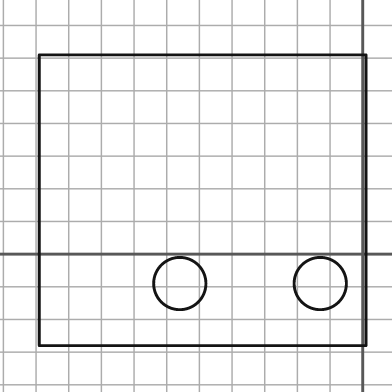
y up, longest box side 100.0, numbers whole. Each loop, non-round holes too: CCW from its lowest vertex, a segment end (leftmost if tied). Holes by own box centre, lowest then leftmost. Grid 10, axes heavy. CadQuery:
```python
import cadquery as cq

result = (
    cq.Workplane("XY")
    .moveTo(-99.0, -28.0)
    .lineTo(1.0, -28.0)
    .lineTo(1.0, 61.0)
    .lineTo(-99.0, 61.0)
    .close()
    .moveTo(-56.0, -9.0)
    .circle(8.0)
    .moveTo(-13.0, -9.0)
    .circle(8.0)
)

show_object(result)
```